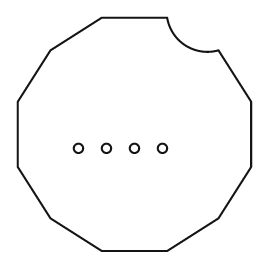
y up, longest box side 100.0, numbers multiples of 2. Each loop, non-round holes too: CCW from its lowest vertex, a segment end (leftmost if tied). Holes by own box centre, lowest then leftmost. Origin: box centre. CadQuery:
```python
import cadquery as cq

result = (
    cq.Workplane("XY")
    .moveTo(-14.0, -50.0)
    .lineTo(14.0, -50.0)
    .lineTo(36.0, -36.0)
    .lineTo(50.0, -14.0)
    .lineTo(50.0, 14.0)
    .lineTo(36.0, 36.0)
    .threePointArc((22.0, 38.0), (14.0, 50.0))
    .lineTo(-14.0, 50.0)
    .lineTo(-36.0, 36.0)
    .lineTo(-50.0, 14.0)
    .lineTo(-50.0, -14.0)
    .lineTo(-36.0, -36.0)
    .close()
    .moveTo(-24.0, -6.0)
    .circle(2.0)
    .moveTo(-12.0, -6.0)
    .circle(2.0)
    .moveTo(0.0, -6.0)
    .circle(2.0)
    .moveTo(12.0, -6.0)
    .circle(2.0)
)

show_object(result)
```